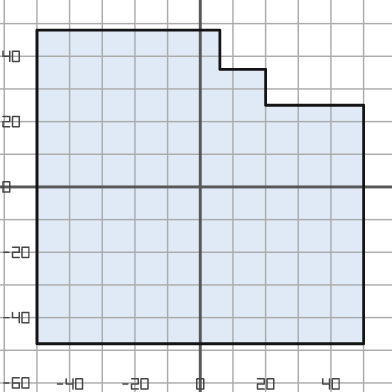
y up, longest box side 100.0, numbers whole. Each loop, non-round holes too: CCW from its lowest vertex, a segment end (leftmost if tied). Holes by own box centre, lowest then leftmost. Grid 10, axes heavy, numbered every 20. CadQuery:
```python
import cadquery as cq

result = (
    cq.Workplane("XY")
    .moveTo(-50.0, -48.0)
    .lineTo(50.0, -48.0)
    .lineTo(50.0, 25.0)
    .lineTo(20.0, 25.0)
    .lineTo(20.0, 36.0)
    .lineTo(6.0, 36.0)
    .lineTo(6.0, 48.0)
    .lineTo(-50.0, 48.0)
    .close()
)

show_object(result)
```